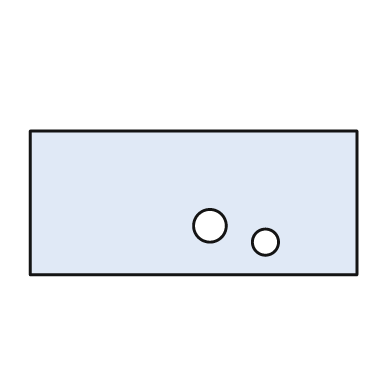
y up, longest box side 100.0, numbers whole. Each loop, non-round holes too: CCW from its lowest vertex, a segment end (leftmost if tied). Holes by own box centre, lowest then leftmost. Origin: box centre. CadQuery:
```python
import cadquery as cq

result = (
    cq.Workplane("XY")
    .moveTo(-50.0, -22.0)
    .lineTo(50.0, -22.0)
    .lineTo(50.0, 22.0)
    .lineTo(-50.0, 22.0)
    .close()
    .moveTo(22.0, -12.0)
    .circle(4.0)
    .moveTo(5.0, -7.0)
    .circle(5.0)
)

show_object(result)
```